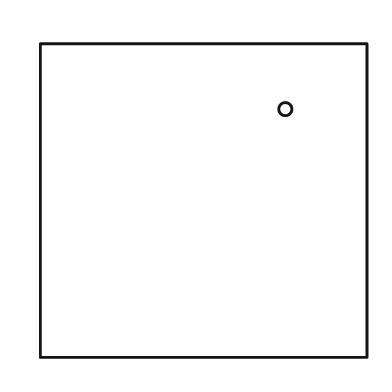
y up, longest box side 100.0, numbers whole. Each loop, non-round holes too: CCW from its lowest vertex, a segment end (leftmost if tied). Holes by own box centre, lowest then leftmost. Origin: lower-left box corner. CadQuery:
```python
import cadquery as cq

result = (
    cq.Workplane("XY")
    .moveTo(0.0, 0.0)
    .lineTo(100.0, 0.0)
    .lineTo(100.0, 96.0)
    .lineTo(0.0, 96.0)
    .close()
    .moveTo(75.0, 76.0)
    .circle(2.0)
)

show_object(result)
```